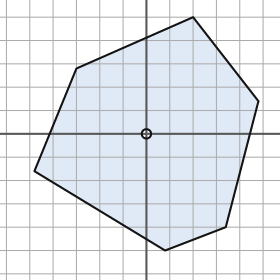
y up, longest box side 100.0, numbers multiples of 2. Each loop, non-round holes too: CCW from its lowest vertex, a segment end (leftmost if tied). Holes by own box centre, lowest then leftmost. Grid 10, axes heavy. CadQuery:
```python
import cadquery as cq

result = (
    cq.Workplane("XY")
    .moveTo(8.0, -50.0)
    .lineTo(34.0, -40.0)
    .lineTo(48.0, 14.0)
    .lineTo(20.0, 50.0)
    .lineTo(-30.0, 28.0)
    .lineTo(-48.0, -16.0)
    .close()
    .moveTo(0.0, 0.0)
    .circle(2.0)
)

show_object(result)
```